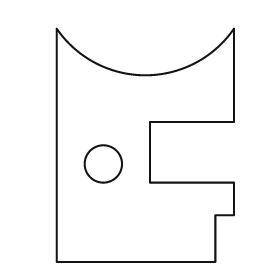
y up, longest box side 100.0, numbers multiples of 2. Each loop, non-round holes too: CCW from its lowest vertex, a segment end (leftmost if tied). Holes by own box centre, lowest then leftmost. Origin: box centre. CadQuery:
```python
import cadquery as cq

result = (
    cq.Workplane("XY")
    .moveTo(-38.0, -50.0)
    .lineTo(30.0, -50.0)
    .lineTo(30.0, -30.0)
    .lineTo(38.0, -30.0)
    .lineTo(38.0, -16.0)
    .lineTo(2.0, -16.0)
    .lineTo(2.0, 10.0)
    .lineTo(38.0, 10.0)
    .lineTo(38.0, 50.0)
    .threePointArc((0.0, 30.0), (-38.0, 50.0))
    .close()
    .moveTo(-18.0, -8.0)
    .circle(8.0)
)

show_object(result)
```